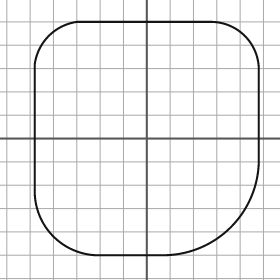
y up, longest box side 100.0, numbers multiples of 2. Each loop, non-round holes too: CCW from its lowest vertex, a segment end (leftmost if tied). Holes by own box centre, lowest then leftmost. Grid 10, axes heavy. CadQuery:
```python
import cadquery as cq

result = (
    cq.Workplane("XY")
    .moveTo(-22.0, -50.0)
    .lineTo(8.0, -50.0)
    .threePointArc((36.0, -38.0), (48.0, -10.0))
    .lineTo(48.0, 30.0)
    .threePointArc((42.0, 44.0), (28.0, 50.0))
    .lineTo(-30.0, 50.0)
    .threePointArc((-42.0, 44.0), (-48.0, 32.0))
    .lineTo(-48.0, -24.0)
    .threePointArc((-40.0, -42.0), (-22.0, -50.0))
    .close()
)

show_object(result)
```